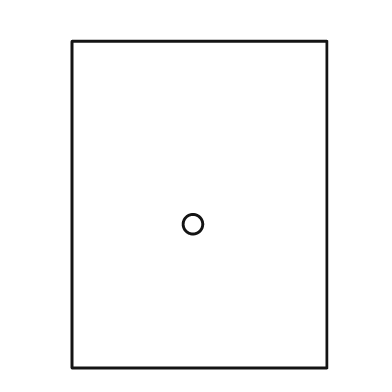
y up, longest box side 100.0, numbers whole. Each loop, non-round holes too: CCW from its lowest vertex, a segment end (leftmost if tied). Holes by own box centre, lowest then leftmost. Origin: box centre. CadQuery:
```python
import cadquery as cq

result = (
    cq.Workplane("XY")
    .moveTo(-39.0, -50.0)
    .lineTo(39.0, -50.0)
    .lineTo(39.0, 50.0)
    .lineTo(-39.0, 50.0)
    .close()
    .moveTo(-2.0, -6.0)
    .circle(3.0)
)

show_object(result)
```